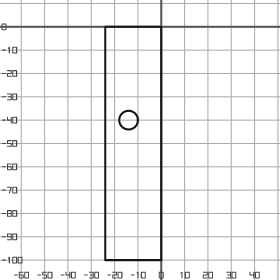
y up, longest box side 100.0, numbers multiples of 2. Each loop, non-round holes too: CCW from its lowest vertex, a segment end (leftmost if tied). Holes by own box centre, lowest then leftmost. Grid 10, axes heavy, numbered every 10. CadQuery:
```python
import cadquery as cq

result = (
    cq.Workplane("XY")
    .moveTo(-24.0, -100.0)
    .lineTo(0.0, -100.0)
    .lineTo(0.0, 0.0)
    .lineTo(-24.0, 0.0)
    .close()
    .moveTo(-14.0, -40.0)
    .circle(4.0)
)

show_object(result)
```